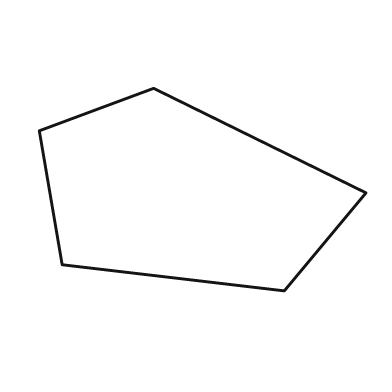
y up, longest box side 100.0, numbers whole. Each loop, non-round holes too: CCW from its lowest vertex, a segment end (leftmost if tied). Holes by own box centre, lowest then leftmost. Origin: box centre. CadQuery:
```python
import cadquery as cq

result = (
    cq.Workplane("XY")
    .moveTo(25.0, -31.0)
    .lineTo(50.0, -1.0)
    .lineTo(-15.0, 31.0)
    .lineTo(-50.0, 18.0)
    .lineTo(-43.0, -23.0)
    .close()
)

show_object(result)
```